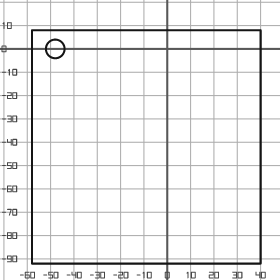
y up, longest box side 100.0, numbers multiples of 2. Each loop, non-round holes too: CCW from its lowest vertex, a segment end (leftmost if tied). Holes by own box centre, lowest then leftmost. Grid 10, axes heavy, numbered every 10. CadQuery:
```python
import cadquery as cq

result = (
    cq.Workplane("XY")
    .moveTo(-58.0, -92.0)
    .lineTo(40.0, -92.0)
    .lineTo(40.0, 8.0)
    .lineTo(-58.0, 8.0)
    .close()
    .moveTo(-48.0, 0.0)
    .circle(4.0)
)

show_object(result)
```